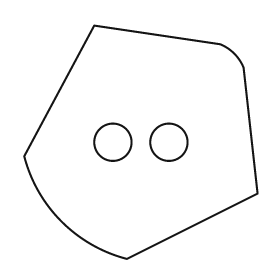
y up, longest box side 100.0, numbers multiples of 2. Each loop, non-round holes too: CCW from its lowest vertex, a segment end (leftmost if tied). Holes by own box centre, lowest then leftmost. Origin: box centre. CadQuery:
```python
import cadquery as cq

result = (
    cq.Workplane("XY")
    .moveTo(-6.0, -50.0)
    .lineTo(50.0, -22.0)
    .lineTo(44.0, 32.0)
    .threePointArc((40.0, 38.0), (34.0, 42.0))
    .lineTo(-20.0, 50.0)
    .lineTo(-50.0, -6.0)
    .threePointArc((-34.0, -34.0), (-6.0, -50.0))
    .close()
    .moveTo(-12.0, 0.0)
    .circle(8.0)
    .moveTo(12.0, 0.0)
    .circle(8.0)
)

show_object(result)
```